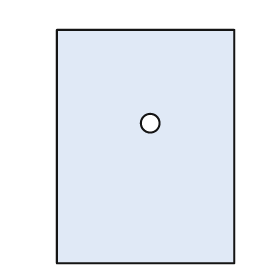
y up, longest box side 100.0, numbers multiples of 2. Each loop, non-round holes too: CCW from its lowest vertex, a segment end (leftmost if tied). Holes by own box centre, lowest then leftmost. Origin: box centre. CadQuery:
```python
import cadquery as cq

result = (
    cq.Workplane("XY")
    .moveTo(-38.0, -50.0)
    .lineTo(38.0, -50.0)
    .lineTo(38.0, 50.0)
    .lineTo(-38.0, 50.0)
    .close()
    .moveTo(2.0, 10.0)
    .circle(4.0)
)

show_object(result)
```